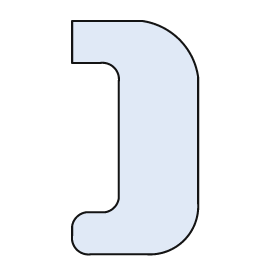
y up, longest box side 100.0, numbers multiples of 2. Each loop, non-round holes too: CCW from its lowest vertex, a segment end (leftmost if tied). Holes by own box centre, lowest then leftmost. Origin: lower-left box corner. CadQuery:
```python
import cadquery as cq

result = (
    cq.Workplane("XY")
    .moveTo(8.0, 0.0)
    .lineTo(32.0, 0.0)
    .threePointArc((48.0, 6.0), (54.0, 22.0))
    .lineTo(54.0, 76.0)
    .threePointArc((46.0, 92.0), (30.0, 100.0))
    .lineTo(0.0, 100.0)
    .lineTo(0.0, 82.0)
    .lineTo(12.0, 82.0)
    .threePointArc((18.0, 80.0), (20.0, 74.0))
    .lineTo(20.0, 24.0)
    .threePointArc((18.0, 20.0), (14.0, 18.0))
    .lineTo(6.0, 18.0)
    .threePointArc((2.0, 16.0), (0.0, 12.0))
    .lineTo(0.0, 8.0)
    .threePointArc((2.0, 2.0), (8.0, 0.0))
    .close()
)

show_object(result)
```